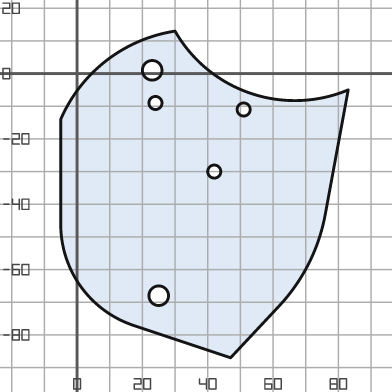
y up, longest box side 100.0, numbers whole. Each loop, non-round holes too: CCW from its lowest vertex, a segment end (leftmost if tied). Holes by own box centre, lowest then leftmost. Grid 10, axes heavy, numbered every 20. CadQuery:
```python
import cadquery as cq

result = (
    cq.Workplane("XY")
    .moveTo(47.0, -87.0)
    .lineTo(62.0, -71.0)
    .threePointArc((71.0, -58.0), (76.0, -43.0))
    .lineTo(83.0, -5.0)
    .threePointArc((53.0, -6.0), (30.0, 13.0))
    .threePointArc((9.0, 4.0), (-5.0, -14.0))
    .lineTo(-5.0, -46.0)
    .threePointArc((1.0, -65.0), (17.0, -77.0))
    .close()
    .moveTo(25.0, -68.0)
    .circle(3.0)
    .moveTo(42.0, -30.0)
    .circle(2.0)
    .moveTo(51.0, -11.0)
    .circle(2.0)
    .moveTo(24.0, -9.0)
    .circle(2.0)
    .moveTo(23.0, 1.0)
    .circle(3.0)
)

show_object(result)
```